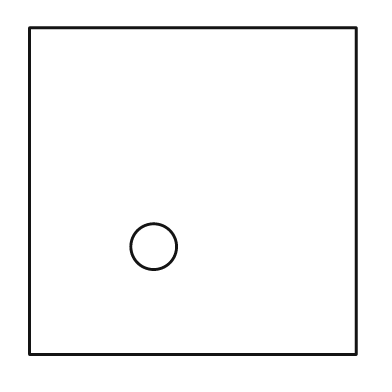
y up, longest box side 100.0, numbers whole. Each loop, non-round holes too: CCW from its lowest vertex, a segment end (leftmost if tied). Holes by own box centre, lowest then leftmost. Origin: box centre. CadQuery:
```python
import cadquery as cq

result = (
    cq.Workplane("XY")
    .moveTo(-50.0, -50.0)
    .lineTo(50.0, -50.0)
    .lineTo(50.0, 50.0)
    .lineTo(-50.0, 50.0)
    .close()
    .moveTo(-12.0, -17.0)
    .circle(7.0)
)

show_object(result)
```